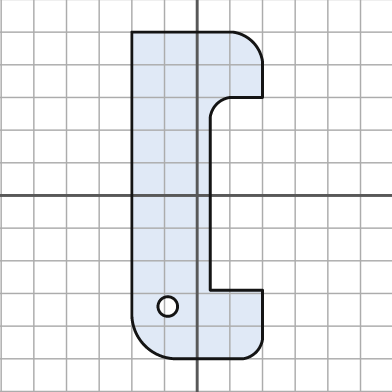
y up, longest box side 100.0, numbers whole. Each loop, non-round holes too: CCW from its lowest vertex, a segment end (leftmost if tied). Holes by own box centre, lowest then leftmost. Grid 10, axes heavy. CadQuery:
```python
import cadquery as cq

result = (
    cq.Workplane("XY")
    .moveTo(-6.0, -50.0)
    .lineTo(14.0, -50.0)
    .threePointArc((18.0, -48.0), (20.0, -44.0))
    .lineTo(20.0, -29.0)
    .lineTo(4.0, -29.0)
    .lineTo(4.0, 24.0)
    .threePointArc((6.0, 28.0), (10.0, 30.0))
    .lineTo(20.0, 30.0)
    .lineTo(20.0, 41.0)
    .threePointArc((17.0, 47.0), (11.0, 50.0))
    .lineTo(-20.0, 50.0)
    .lineTo(-20.0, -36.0)
    .threePointArc((-16.0, -46.0), (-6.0, -50.0))
    .close()
    .moveTo(-9.0, -34.0)
    .circle(3.0)
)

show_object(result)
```